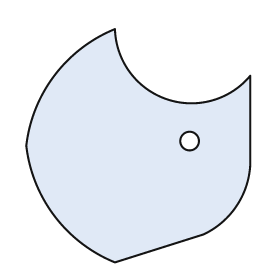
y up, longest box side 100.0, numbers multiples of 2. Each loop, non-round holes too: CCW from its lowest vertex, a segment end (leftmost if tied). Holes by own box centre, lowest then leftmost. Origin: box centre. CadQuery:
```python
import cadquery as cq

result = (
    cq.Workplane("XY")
    .moveTo(-10.0, -50.0)
    .lineTo(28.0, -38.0)
    .threePointArc((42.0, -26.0), (48.0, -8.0))
    .lineTo(48.0, 30.0)
    .threePointArc((12.0, 20.0), (-10.0, 50.0))
    .threePointArc((-36.0, 30.0), (-48.0, 0.0))
    .threePointArc((-36.0, -30.0), (-10.0, -50.0))
    .close()
    .moveTo(22.0, 2.0)
    .circle(4.0)
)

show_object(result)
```